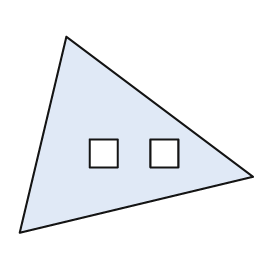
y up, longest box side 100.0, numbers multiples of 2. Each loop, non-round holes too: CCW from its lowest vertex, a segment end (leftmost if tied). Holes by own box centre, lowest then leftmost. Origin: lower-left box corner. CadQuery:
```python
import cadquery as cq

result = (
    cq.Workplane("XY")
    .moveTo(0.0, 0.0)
    .lineTo(100.0, 24.0)
    .lineTo(20.0, 84.0)
    .close()
    .moveTo(30.0, 28.0)
    .lineTo(42.0, 28.0)
    .lineTo(42.0, 40.0)
    .lineTo(30.0, 40.0)
    .close()
    .moveTo(56.0, 28.0)
    .lineTo(68.0, 28.0)
    .lineTo(68.0, 40.0)
    .lineTo(56.0, 40.0)
    .close()
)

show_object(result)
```